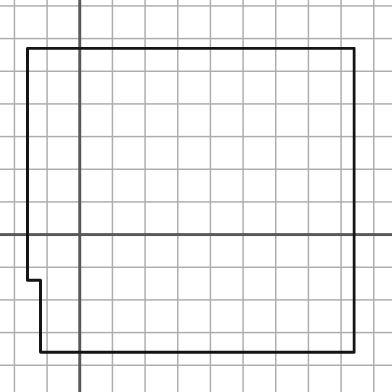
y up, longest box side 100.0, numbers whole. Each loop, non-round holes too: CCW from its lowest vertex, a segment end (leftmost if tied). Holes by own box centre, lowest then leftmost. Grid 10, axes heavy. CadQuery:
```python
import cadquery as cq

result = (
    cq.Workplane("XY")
    .moveTo(-12.0, -36.0)
    .lineTo(84.0, -36.0)
    .lineTo(84.0, 57.0)
    .lineTo(-16.0, 57.0)
    .lineTo(-16.0, -14.0)
    .lineTo(-12.0, -14.0)
    .close()
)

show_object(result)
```